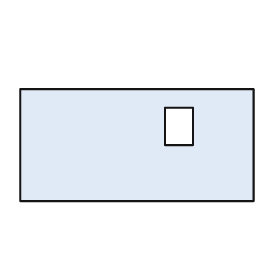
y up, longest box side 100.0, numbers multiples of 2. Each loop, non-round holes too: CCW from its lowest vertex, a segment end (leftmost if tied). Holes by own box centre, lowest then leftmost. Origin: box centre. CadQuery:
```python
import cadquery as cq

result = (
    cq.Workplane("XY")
    .moveTo(-50.0, -24.0)
    .lineTo(50.0, -24.0)
    .lineTo(50.0, 24.0)
    .lineTo(-50.0, 24.0)
    .close()
    .moveTo(12.0, 0.0)
    .lineTo(24.0, 0.0)
    .lineTo(24.0, 16.0)
    .lineTo(12.0, 16.0)
    .close()
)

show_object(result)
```